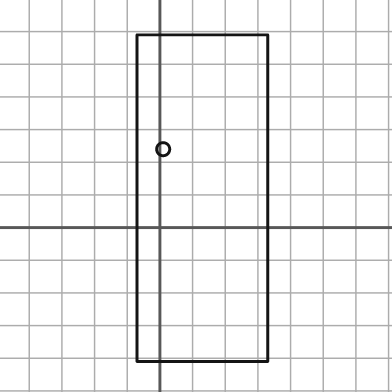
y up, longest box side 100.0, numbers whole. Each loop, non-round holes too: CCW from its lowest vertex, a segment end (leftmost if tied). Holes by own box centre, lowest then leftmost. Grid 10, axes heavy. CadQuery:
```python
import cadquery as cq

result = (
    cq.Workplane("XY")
    .moveTo(-7.0, -41.0)
    .lineTo(33.0, -41.0)
    .lineTo(33.0, 59.0)
    .lineTo(-7.0, 59.0)
    .close()
    .moveTo(1.0, 24.0)
    .circle(2.0)
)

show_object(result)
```